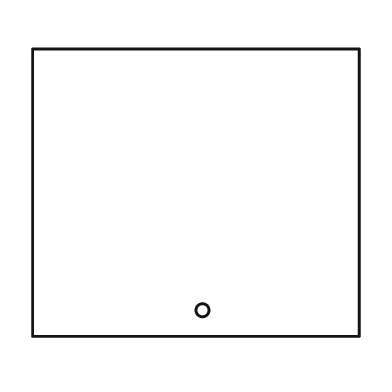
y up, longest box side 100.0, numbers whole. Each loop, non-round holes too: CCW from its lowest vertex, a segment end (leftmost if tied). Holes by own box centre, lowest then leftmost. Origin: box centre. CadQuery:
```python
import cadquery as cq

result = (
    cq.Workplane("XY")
    .moveTo(-50.0, -44.0)
    .lineTo(50.0, -44.0)
    .lineTo(50.0, 44.0)
    .lineTo(-50.0, 44.0)
    .close()
    .moveTo(2.0, -36.0)
    .circle(2.0)
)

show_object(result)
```